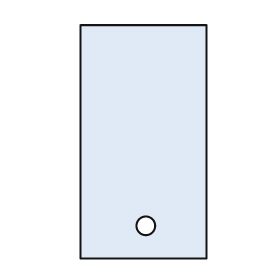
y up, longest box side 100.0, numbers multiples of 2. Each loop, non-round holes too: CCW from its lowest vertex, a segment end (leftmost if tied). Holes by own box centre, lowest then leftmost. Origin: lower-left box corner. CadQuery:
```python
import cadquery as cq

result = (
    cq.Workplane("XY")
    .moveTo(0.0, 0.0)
    .lineTo(54.0, 0.0)
    .lineTo(54.0, 100.0)
    .lineTo(0.0, 100.0)
    .close()
    .moveTo(28.0, 14.0)
    .circle(4.0)
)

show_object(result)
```